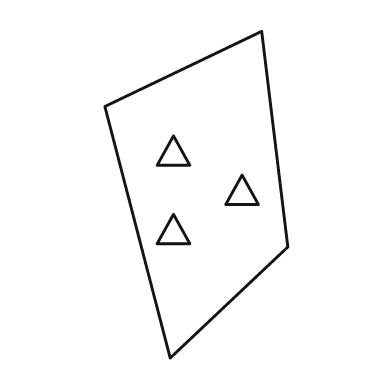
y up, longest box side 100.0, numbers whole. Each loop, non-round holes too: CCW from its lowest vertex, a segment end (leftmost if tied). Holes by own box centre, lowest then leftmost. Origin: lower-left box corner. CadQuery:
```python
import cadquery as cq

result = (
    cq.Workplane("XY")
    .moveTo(20.0, 0.0)
    .lineTo(56.0, 34.0)
    .lineTo(48.0, 100.0)
    .lineTo(0.0, 77.0)
    .close()
    .moveTo(16.0, 35.0)
    .lineTo(26.0, 35.0)
    .lineTo(21.0, 44.0)
    .close()
    .moveTo(37.0, 47.0)
    .lineTo(47.0, 47.0)
    .lineTo(42.0, 56.0)
    .close()
    .moveTo(16.0, 59.0)
    .lineTo(26.0, 59.0)
    .lineTo(21.0, 68.0)
    .close()
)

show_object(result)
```